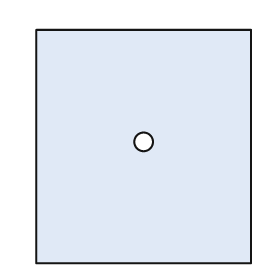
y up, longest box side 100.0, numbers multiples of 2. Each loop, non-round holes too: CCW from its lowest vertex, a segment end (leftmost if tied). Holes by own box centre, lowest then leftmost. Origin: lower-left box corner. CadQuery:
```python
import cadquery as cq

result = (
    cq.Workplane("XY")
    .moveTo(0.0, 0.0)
    .lineTo(92.0, 0.0)
    .lineTo(92.0, 100.0)
    .lineTo(0.0, 100.0)
    .close()
    .moveTo(46.0, 52.0)
    .circle(4.0)
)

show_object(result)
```